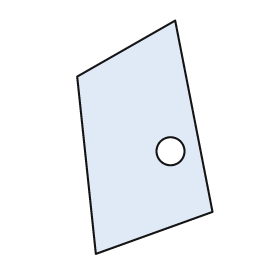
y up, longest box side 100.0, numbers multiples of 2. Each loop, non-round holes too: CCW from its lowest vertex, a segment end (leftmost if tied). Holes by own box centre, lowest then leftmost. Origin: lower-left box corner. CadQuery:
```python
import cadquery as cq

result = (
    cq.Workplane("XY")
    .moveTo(8.0, 0.0)
    .lineTo(58.0, 18.0)
    .lineTo(42.0, 100.0)
    .lineTo(0.0, 76.0)
    .close()
    .moveTo(40.0, 44.0)
    .circle(6.0)
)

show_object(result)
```